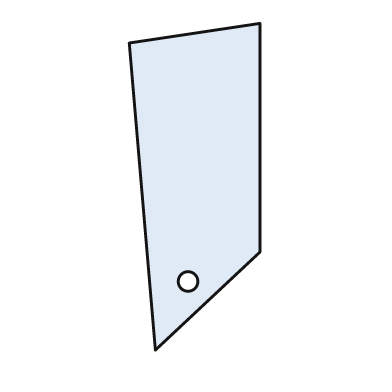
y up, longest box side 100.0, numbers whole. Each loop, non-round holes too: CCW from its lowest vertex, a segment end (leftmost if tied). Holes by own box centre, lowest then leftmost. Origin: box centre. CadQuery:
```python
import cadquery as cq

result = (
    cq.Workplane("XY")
    .moveTo(-12.0, -50.0)
    .lineTo(20.0, -20.0)
    .lineTo(20.0, 50.0)
    .lineTo(-20.0, 44.0)
    .close()
    .moveTo(-2.0, -29.0)
    .circle(3.0)
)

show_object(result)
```